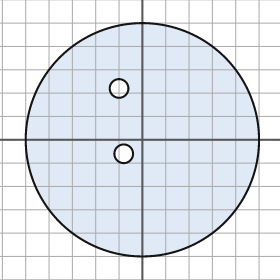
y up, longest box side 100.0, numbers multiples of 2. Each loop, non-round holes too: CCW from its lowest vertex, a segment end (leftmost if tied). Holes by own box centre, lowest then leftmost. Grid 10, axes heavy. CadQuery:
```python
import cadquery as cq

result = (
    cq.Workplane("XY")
    .moveTo(0.0, 0.0)
    .circle(50.0)
    .moveTo(-8.0, -6.0)
    .circle(4.0)
    .moveTo(-10.0, 22.0)
    .circle(4.0)
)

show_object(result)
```